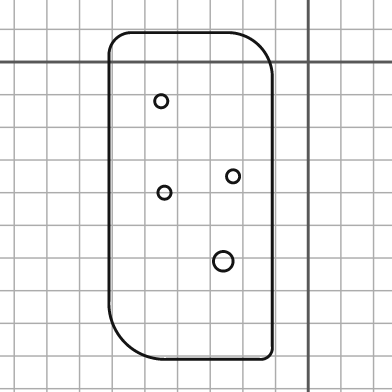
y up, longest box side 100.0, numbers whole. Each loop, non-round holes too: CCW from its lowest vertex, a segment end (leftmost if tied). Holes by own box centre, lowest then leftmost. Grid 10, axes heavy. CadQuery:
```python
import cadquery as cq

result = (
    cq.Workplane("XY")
    .moveTo(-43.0, -91.0)
    .lineTo(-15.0, -91.0)
    .threePointArc((-12.0, -90.0), (-11.0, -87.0))
    .lineTo(-11.0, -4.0)
    .threePointArc((-15.0, 5.0), (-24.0, 9.0))
    .lineTo(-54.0, 9.0)
    .threePointArc((-59.0, 7.0), (-61.0, 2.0))
    .lineTo(-61.0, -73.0)
    .threePointArc((-56.0, -86.0), (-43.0, -91.0))
    .close()
    .moveTo(-26.0, -61.0)
    .circle(3.0)
    .moveTo(-44.0, -40.0)
    .circle(2.0)
    .moveTo(-23.0, -35.0)
    .circle(2.0)
    .moveTo(-45.0, -12.0)
    .circle(2.0)
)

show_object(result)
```